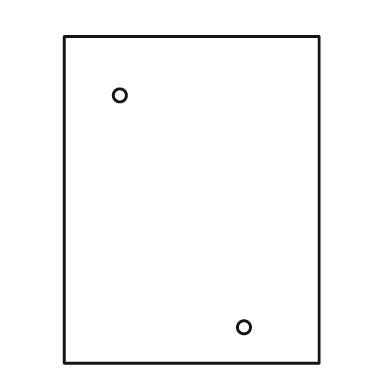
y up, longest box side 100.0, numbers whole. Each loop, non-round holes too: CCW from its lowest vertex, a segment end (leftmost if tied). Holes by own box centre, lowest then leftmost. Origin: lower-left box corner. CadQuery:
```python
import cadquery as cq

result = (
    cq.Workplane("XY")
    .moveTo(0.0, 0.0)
    .lineTo(78.0, 0.0)
    .lineTo(78.0, 100.0)
    .lineTo(0.0, 100.0)
    .close()
    .moveTo(55.0, 11.0)
    .circle(2.0)
    .moveTo(17.0, 82.0)
    .circle(2.0)
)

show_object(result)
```